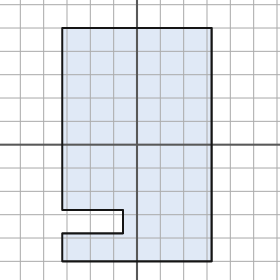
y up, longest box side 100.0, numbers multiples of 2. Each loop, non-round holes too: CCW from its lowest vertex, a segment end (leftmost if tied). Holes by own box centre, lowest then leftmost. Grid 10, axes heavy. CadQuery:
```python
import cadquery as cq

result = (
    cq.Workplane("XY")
    .moveTo(-32.0, -50.0)
    .lineTo(32.0, -50.0)
    .lineTo(32.0, 50.0)
    .lineTo(-32.0, 50.0)
    .lineTo(-32.0, -28.0)
    .lineTo(-6.0, -28.0)
    .lineTo(-6.0, -38.0)
    .lineTo(-32.0, -38.0)
    .close()
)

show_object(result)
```